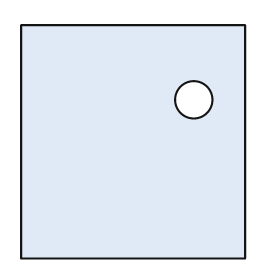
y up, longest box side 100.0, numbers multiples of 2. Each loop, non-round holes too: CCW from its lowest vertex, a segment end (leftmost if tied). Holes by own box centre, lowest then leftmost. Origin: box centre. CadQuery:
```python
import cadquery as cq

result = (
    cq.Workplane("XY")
    .moveTo(-48.0, -50.0)
    .lineTo(48.0, -50.0)
    .lineTo(48.0, 50.0)
    .lineTo(-48.0, 50.0)
    .close()
    .moveTo(26.0, 18.0)
    .circle(8.0)
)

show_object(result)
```